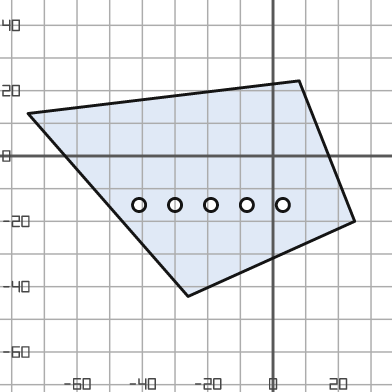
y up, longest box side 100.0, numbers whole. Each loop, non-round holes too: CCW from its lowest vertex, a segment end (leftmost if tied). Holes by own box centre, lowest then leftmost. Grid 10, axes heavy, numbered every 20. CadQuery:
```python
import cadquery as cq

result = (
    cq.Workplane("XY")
    .moveTo(-26.0, -43.0)
    .lineTo(25.0, -20.0)
    .lineTo(8.0, 23.0)
    .lineTo(-75.0, 13.0)
    .close()
    .moveTo(-41.0, -15.0)
    .circle(2.0)
    .moveTo(-30.0, -15.0)
    .circle(2.0)
    .moveTo(-19.0, -15.0)
    .circle(2.0)
    .moveTo(-8.0, -15.0)
    .circle(2.0)
    .moveTo(3.0, -15.0)
    .circle(2.0)
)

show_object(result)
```